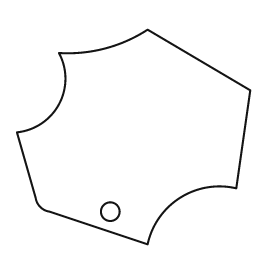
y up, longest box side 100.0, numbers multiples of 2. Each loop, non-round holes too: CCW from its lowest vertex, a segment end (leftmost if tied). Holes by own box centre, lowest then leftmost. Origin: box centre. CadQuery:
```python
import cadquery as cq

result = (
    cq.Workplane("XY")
    .moveTo(6.0, -46.0)
    .threePointArc((20.0, -26.0), (44.0, -22.0))
    .lineTo(50.0, 20.0)
    .lineTo(6.0, 46.0)
    .threePointArc((-12.0, 38.0), (-32.0, 36.0))
    .threePointArc((-32.0, 14.0), (-50.0, 2.0))
    .lineTo(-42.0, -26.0)
    .threePointArc((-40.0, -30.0), (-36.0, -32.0))
    .close()
    .moveTo(-10.0, -32.0)
    .circle(4.0)
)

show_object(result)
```